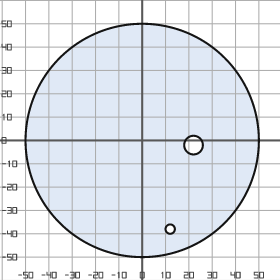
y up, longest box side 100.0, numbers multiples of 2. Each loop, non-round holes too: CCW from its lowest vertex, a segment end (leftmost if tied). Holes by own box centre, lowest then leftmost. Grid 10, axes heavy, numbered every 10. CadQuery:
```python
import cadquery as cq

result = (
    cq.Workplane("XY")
    .moveTo(0.0, 0.0)
    .circle(50.0)
    .moveTo(12.0, -38.0)
    .circle(2.0)
    .moveTo(22.0, -2.0)
    .circle(4.0)
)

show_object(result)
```